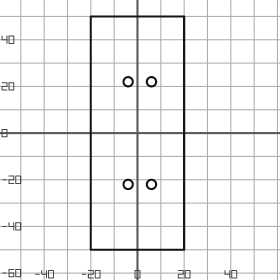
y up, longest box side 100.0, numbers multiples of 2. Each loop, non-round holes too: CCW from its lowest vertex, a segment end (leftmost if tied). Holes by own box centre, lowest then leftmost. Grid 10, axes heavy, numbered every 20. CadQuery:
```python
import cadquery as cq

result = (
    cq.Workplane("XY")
    .moveTo(-20.0, -50.0)
    .lineTo(20.0, -50.0)
    .lineTo(20.0, 50.0)
    .lineTo(-20.0, 50.0)
    .close()
    .moveTo(-4.0, -22.0)
    .circle(2.0)
    .moveTo(6.0, -22.0)
    .circle(2.0)
    .moveTo(-4.0, 22.0)
    .circle(2.0)
    .moveTo(6.0, 22.0)
    .circle(2.0)
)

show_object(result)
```